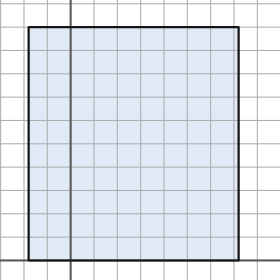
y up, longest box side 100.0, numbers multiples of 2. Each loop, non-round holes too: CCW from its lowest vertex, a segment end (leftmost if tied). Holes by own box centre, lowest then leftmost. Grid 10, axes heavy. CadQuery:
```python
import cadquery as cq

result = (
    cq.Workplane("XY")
    .moveTo(-18.0, 0.0)
    .lineTo(72.0, 0.0)
    .lineTo(72.0, 100.0)
    .lineTo(-18.0, 100.0)
    .close()
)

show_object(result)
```